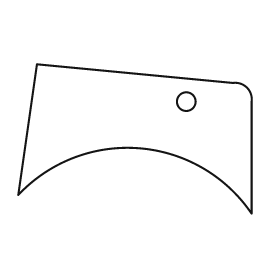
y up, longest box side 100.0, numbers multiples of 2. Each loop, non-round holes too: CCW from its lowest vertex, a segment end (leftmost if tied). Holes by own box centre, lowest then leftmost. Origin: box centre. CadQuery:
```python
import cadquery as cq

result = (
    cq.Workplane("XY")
    .moveTo(50.0, -32.0)
    .lineTo(50.0, 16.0)
    .threePointArc((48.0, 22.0), (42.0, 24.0))
    .lineTo(-42.0, 32.0)
    .lineTo(-50.0, -24.0)
    .threePointArc((2.0, -4.0), (50.0, -32.0))
    .close()
    .moveTo(22.0, 16.0)
    .circle(4.0)
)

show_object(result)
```